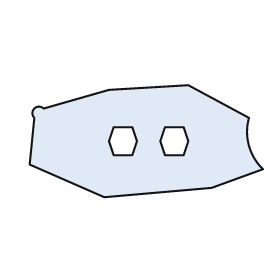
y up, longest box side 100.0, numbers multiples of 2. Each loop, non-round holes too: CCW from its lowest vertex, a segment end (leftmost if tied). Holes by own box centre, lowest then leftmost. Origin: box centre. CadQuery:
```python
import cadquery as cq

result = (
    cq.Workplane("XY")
    .moveTo(-18.0, -24.0)
    .lineTo(28.0, -20.0)
    .lineTo(50.0, -12.0)
    .threePointArc((44.0, -2.0), (44.0, 10.0))
    .lineTo(18.0, 24.0)
    .lineTo(-16.0, 22.0)
    .lineTo(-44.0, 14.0)
    .threePointArc((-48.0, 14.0), (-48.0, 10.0))
    .lineTo(-50.0, -10.0)
    .close()
    .moveTo(-14.0, -6.0)
    .lineTo(-6.0, -6.0)
    .lineTo(-4.0, 0.0)
    .lineTo(-6.0, 6.0)
    .lineTo(-14.0, 6.0)
    .lineTo(-16.0, 0.0)
    .close()
    .moveTo(8.0, -6.0)
    .lineTo(16.0, -6.0)
    .lineTo(18.0, 0.0)
    .lineTo(16.0, 6.0)
    .lineTo(8.0, 6.0)
    .lineTo(6.0, 0.0)
    .close()
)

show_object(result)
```